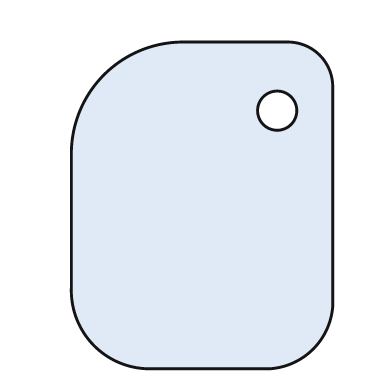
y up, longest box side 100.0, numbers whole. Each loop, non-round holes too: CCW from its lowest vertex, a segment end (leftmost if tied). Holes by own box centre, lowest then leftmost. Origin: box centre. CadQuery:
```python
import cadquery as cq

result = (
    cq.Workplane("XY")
    .moveTo(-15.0, -50.0)
    .lineTo(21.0, -50.0)
    .threePointArc((34.0, -44.0), (40.0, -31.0))
    .lineTo(40.0, 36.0)
    .threePointArc((36.0, 46.0), (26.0, 50.0))
    .lineTo(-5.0, 50.0)
    .threePointArc((-30.0, 40.0), (-40.0, 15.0))
    .lineTo(-40.0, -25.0)
    .threePointArc((-33.0, -43.0), (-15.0, -50.0))
    .close()
    .moveTo(23.0, 29.0)
    .circle(6.0)
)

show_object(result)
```